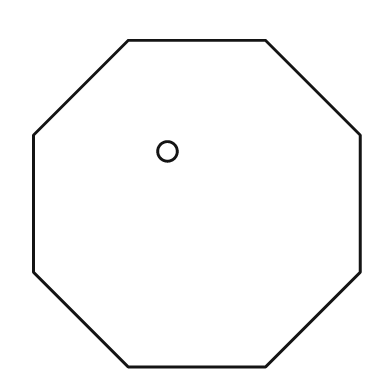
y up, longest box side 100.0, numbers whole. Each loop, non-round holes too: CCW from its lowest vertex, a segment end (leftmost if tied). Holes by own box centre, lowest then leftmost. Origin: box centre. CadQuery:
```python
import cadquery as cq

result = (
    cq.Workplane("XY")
    .moveTo(-21.0, -50.0)
    .lineTo(21.0, -50.0)
    .lineTo(50.0, -21.0)
    .lineTo(50.0, 21.0)
    .lineTo(21.0, 50.0)
    .lineTo(-21.0, 50.0)
    .lineTo(-50.0, 21.0)
    .lineTo(-50.0, -21.0)
    .close()
    .moveTo(-9.0, 16.0)
    .circle(3.0)
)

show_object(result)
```